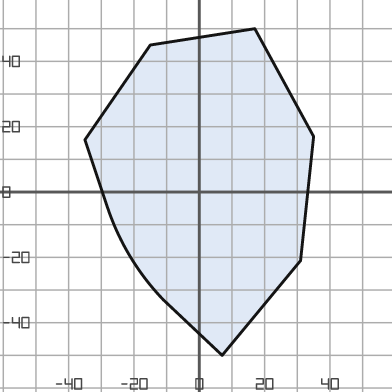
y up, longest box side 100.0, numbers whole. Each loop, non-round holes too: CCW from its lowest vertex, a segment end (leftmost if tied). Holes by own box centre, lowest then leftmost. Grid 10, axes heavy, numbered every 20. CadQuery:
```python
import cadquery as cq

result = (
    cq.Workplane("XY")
    .moveTo(7.0, -50.0)
    .lineTo(31.0, -21.0)
    .lineTo(35.0, 17.0)
    .lineTo(17.0, 50.0)
    .lineTo(-15.0, 45.0)
    .lineTo(-35.0, 16.0)
    .lineTo(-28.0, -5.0)
    .threePointArc((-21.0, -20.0), (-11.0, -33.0))
    .close()
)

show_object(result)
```